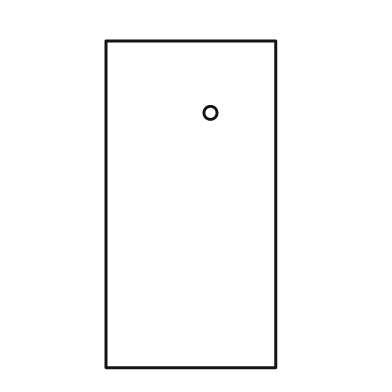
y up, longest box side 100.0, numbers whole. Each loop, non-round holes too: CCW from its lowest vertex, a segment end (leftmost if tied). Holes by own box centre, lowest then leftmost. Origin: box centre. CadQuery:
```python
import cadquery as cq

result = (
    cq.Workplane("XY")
    .moveTo(-26.0, -50.0)
    .lineTo(26.0, -50.0)
    .lineTo(26.0, 50.0)
    .lineTo(-26.0, 50.0)
    .close()
    .moveTo(6.0, 28.0)
    .circle(2.0)
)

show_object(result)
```